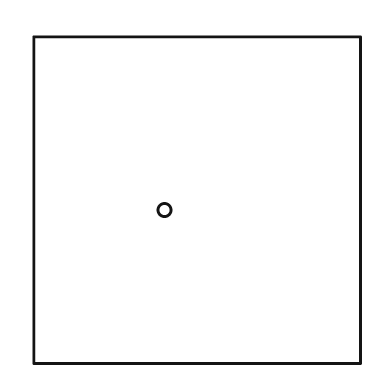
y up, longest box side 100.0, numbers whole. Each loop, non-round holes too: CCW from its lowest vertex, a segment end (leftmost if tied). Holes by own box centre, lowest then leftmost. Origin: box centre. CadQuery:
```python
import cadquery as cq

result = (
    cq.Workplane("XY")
    .moveTo(-50.0, -50.0)
    .lineTo(50.0, -50.0)
    .lineTo(50.0, 50.0)
    .lineTo(-50.0, 50.0)
    .close()
    .moveTo(-10.0, -3.0)
    .circle(2.0)
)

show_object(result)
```